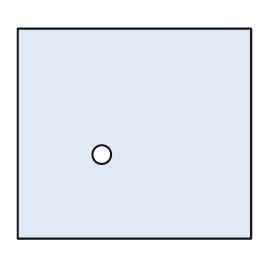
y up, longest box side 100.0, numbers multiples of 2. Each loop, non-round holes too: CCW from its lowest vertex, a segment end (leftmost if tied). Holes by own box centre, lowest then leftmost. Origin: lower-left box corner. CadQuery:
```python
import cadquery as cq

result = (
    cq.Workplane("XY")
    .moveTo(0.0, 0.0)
    .lineTo(100.0, 0.0)
    .lineTo(100.0, 90.0)
    .lineTo(0.0, 90.0)
    .close()
    .moveTo(36.0, 36.0)
    .circle(4.0)
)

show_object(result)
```